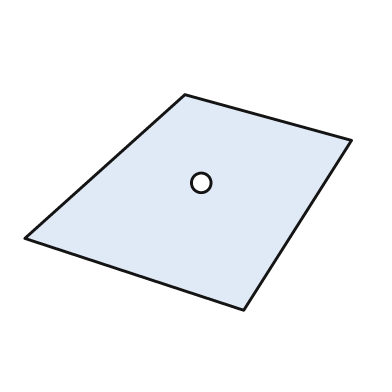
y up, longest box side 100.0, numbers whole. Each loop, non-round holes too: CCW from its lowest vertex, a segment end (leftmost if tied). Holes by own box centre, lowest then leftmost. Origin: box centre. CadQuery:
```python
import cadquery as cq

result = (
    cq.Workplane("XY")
    .moveTo(17.0, -33.0)
    .lineTo(50.0, 19.0)
    .lineTo(-1.0, 33.0)
    .lineTo(-50.0, -11.0)
    .close()
    .moveTo(4.0, 6.0)
    .circle(3.0)
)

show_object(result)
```